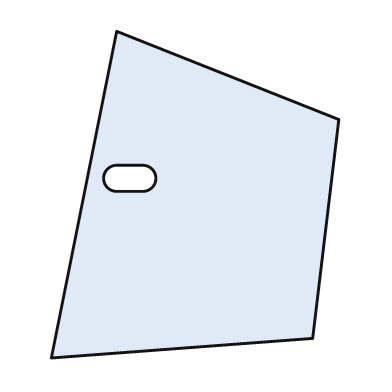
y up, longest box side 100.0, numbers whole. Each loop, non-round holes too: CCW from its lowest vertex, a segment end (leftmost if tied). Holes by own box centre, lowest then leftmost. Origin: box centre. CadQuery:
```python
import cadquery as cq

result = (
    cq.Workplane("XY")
    .moveTo(-44.0, -50.0)
    .lineTo(36.0, -44.0)
    .lineTo(44.0, 23.0)
    .lineTo(-24.0, 50.0)
    .close()
    .moveTo(-24.0, 1.0)
    .lineTo(-16.0, 1.0)
    .threePointArc((-12.0, 5.0), (-16.0, 9.0))
    .lineTo(-24.0, 9.0)
    .threePointArc((-28.0, 5.0), (-24.0, 1.0))
    .close()
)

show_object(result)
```